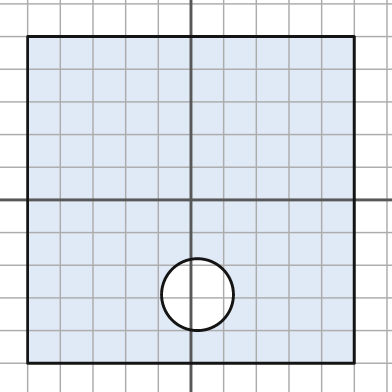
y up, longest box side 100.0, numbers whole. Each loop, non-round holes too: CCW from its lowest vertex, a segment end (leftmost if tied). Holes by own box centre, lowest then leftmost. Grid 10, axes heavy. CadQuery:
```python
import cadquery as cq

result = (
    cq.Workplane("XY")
    .moveTo(-50.0, -50.0)
    .lineTo(50.0, -50.0)
    .lineTo(50.0, 50.0)
    .lineTo(-50.0, 50.0)
    .close()
    .moveTo(2.0, -29.0)
    .circle(11.0)
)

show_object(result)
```